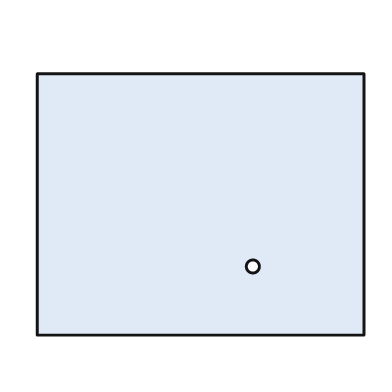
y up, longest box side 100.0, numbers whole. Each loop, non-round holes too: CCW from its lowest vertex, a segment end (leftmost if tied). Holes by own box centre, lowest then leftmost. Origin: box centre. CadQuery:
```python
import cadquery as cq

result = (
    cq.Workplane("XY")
    .moveTo(-50.0, -40.0)
    .lineTo(50.0, -40.0)
    .lineTo(50.0, 40.0)
    .lineTo(-50.0, 40.0)
    .close()
    .moveTo(16.0, -19.0)
    .circle(2.0)
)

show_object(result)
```